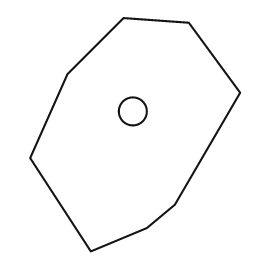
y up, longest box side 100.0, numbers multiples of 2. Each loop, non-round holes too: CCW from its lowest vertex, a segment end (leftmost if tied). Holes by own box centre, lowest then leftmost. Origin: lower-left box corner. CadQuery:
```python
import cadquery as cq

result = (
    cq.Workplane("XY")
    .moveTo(26.0, 0.0)
    .lineTo(50.0, 10.0)
    .lineTo(62.0, 20.0)
    .lineTo(90.0, 68.0)
    .lineTo(68.0, 98.0)
    .lineTo(40.0, 100.0)
    .lineTo(16.0, 76.0)
    .lineTo(0.0, 40.0)
    .close()
    .moveTo(44.0, 60.0)
    .circle(6.0)
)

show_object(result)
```